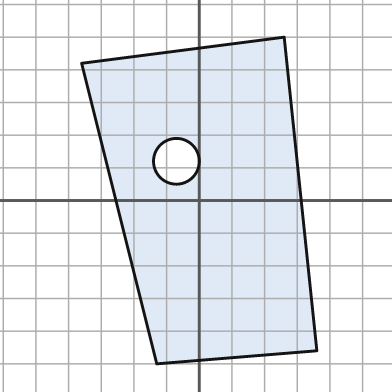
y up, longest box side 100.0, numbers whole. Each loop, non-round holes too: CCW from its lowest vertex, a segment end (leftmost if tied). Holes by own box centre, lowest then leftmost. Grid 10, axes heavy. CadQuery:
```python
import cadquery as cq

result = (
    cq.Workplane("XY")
    .moveTo(-13.0, -50.0)
    .lineTo(36.0, -46.0)
    .lineTo(26.0, 50.0)
    .lineTo(-36.0, 42.0)
    .close()
    .moveTo(-7.0, 12.0)
    .circle(7.0)
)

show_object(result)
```